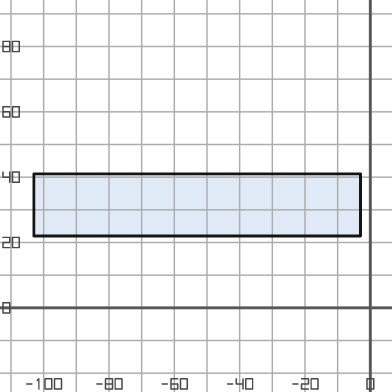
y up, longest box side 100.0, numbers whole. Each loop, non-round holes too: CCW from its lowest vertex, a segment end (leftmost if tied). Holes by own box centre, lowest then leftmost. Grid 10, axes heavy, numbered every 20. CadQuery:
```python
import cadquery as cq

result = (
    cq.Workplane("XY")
    .moveTo(-103.0, 22.0)
    .lineTo(-3.0, 22.0)
    .lineTo(-3.0, 41.0)
    .lineTo(-103.0, 41.0)
    .close()
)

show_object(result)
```